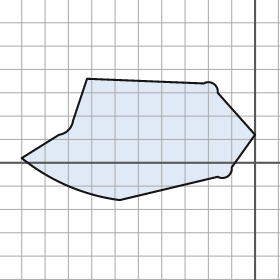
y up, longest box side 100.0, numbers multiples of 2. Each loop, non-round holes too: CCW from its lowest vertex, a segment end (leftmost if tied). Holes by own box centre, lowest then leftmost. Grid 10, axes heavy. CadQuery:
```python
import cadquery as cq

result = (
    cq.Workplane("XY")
    .moveTo(-58.0, -16.0)
    .lineTo(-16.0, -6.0)
    .threePointArc((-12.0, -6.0), (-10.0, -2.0))
    .lineTo(0.0, 12.0)
    .lineTo(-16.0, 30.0)
    .threePointArc((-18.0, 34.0), (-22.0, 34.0))
    .lineTo(-72.0, 36.0)
    .lineTo(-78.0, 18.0)
    .threePointArc((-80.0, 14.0), (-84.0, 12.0))
    .lineTo(-100.0, 2.0)
    .threePointArc((-80.0, -10.0), (-58.0, -16.0))
    .close()
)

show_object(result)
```